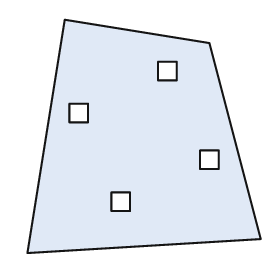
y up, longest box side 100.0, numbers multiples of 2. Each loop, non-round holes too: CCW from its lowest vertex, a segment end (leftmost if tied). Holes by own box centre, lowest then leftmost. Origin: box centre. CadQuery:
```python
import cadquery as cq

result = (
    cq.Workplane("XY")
    .moveTo(-50.0, -50.0)
    .lineTo(50.0, -44.0)
    .lineTo(28.0, 40.0)
    .lineTo(-34.0, 50.0)
    .close()
    .moveTo(-14.0, -32.0)
    .lineTo(-6.0, -32.0)
    .lineTo(-6.0, -24.0)
    .lineTo(-14.0, -24.0)
    .close()
    .moveTo(24.0, -14.0)
    .lineTo(32.0, -14.0)
    .lineTo(32.0, -6.0)
    .lineTo(24.0, -6.0)
    .close()
    .moveTo(-32.0, 6.0)
    .lineTo(-24.0, 6.0)
    .lineTo(-24.0, 14.0)
    .lineTo(-32.0, 14.0)
    .close()
    .moveTo(6.0, 24.0)
    .lineTo(14.0, 24.0)
    .lineTo(14.0, 32.0)
    .lineTo(6.0, 32.0)
    .close()
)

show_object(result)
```